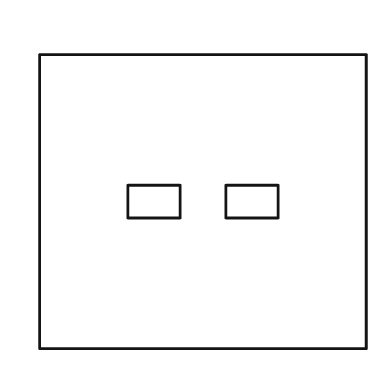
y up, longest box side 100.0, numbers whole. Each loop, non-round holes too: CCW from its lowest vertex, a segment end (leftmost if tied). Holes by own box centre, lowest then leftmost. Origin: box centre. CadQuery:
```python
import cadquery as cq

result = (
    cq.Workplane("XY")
    .moveTo(-50.0, -45.0)
    .lineTo(50.0, -45.0)
    .lineTo(50.0, 45.0)
    .lineTo(-50.0, 45.0)
    .close()
    .moveTo(-23.0, -5.0)
    .lineTo(-7.0, -5.0)
    .lineTo(-7.0, 5.0)
    .lineTo(-23.0, 5.0)
    .close()
    .moveTo(7.0, -5.0)
    .lineTo(23.0, -5.0)
    .lineTo(23.0, 5.0)
    .lineTo(7.0, 5.0)
    .close()
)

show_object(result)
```